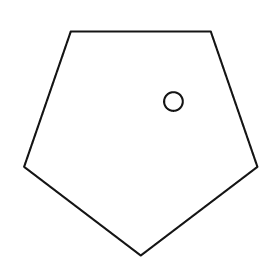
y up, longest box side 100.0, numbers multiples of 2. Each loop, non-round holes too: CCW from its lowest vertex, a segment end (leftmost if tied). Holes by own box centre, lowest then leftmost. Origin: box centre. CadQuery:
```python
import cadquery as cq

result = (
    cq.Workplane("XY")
    .moveTo(0.0, -48.0)
    .lineTo(50.0, -10.0)
    .lineTo(30.0, 48.0)
    .lineTo(-30.0, 48.0)
    .lineTo(-50.0, -10.0)
    .close()
    .moveTo(14.0, 18.0)
    .circle(4.0)
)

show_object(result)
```